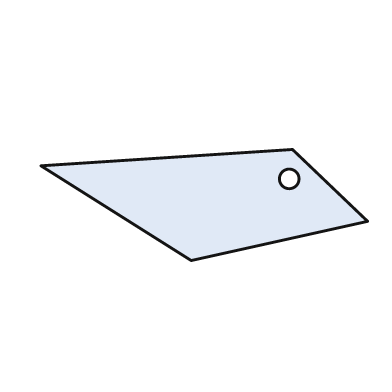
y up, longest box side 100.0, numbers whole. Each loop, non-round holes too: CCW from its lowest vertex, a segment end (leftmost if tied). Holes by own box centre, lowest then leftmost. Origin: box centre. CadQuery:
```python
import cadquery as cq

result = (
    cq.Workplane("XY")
    .moveTo(-4.0, -17.0)
    .lineTo(50.0, -5.0)
    .lineTo(27.0, 17.0)
    .lineTo(-50.0, 12.0)
    .close()
    .moveTo(26.0, 8.0)
    .circle(3.0)
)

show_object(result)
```